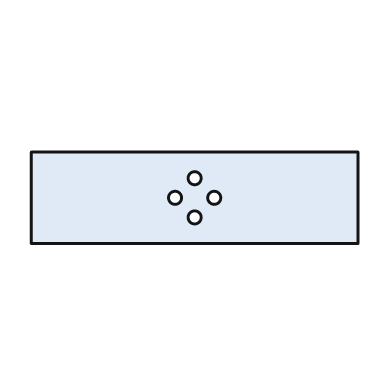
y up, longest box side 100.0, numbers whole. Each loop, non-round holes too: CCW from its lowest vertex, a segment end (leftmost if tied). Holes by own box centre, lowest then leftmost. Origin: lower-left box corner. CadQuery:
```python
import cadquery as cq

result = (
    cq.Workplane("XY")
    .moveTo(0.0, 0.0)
    .lineTo(100.0, 0.0)
    .lineTo(100.0, 28.0)
    .lineTo(0.0, 28.0)
    .close()
    .moveTo(50.0, 8.0)
    .circle(2.0)
    .moveTo(44.0, 14.0)
    .circle(2.0)
    .moveTo(56.0, 14.0)
    .circle(2.0)
    .moveTo(50.0, 20.0)
    .circle(2.0)
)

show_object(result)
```